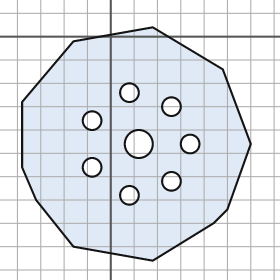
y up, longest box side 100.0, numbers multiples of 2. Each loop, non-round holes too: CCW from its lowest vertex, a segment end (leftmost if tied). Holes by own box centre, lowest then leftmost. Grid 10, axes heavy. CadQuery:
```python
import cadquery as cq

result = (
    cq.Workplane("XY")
    .moveTo(18.0, -96.0)
    .lineTo(44.0, -80.0)
    .lineTo(50.0, -74.0)
    .lineTo(60.0, -46.0)
    .lineTo(48.0, -14.0)
    .lineTo(18.0, 4.0)
    .lineTo(-16.0, -2.0)
    .lineTo(-38.0, -28.0)
    .lineTo(-38.0, -56.0)
    .lineTo(-32.0, -70.0)
    .lineTo(-16.0, -90.0)
    .close()
    .moveTo(8.0, -68.0)
    .circle(4.0)
    .moveTo(26.0, -62.0)
    .circle(4.0)
    .moveTo(-8.0, -56.0)
    .circle(4.0)
    .moveTo(12.0, -46.0)
    .circle(6.0)
    .moveTo(34.0, -46.0)
    .circle(4.0)
    .moveTo(-8.0, -36.0)
    .circle(4.0)
    .moveTo(26.0, -30.0)
    .circle(4.0)
    .moveTo(8.0, -24.0)
    .circle(4.0)
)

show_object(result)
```